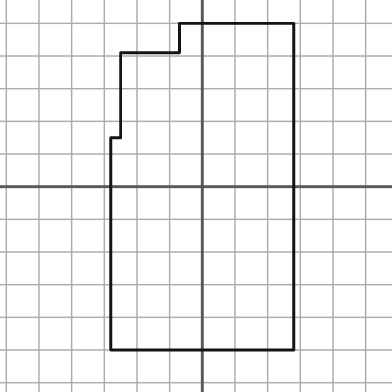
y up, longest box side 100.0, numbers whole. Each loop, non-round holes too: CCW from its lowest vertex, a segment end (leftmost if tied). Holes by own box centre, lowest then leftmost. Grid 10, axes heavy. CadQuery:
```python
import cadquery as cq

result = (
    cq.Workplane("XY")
    .moveTo(-28.0, -50.0)
    .lineTo(28.0, -50.0)
    .lineTo(28.0, 50.0)
    .lineTo(-7.0, 50.0)
    .lineTo(-7.0, 41.0)
    .lineTo(-25.0, 41.0)
    .lineTo(-25.0, 15.0)
    .lineTo(-28.0, 15.0)
    .close()
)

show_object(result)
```